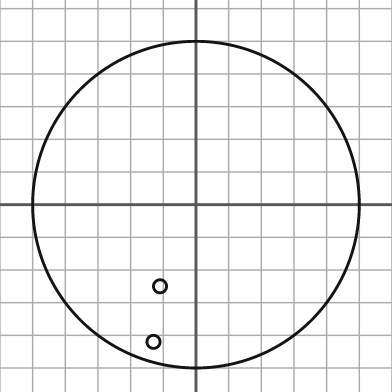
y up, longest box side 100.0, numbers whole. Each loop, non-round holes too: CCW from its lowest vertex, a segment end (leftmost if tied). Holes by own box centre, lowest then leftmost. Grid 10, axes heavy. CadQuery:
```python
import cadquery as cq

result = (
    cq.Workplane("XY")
    .moveTo(0.0, 0.0)
    .circle(50.0)
    .moveTo(-13.0, -42.0)
    .circle(2.0)
    .moveTo(-11.0, -25.0)
    .circle(2.0)
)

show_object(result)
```